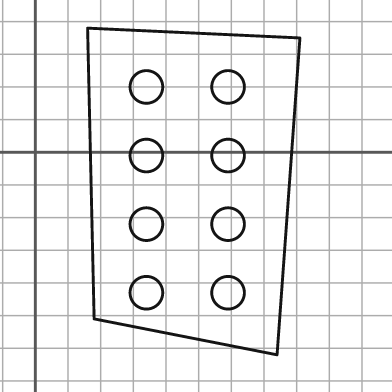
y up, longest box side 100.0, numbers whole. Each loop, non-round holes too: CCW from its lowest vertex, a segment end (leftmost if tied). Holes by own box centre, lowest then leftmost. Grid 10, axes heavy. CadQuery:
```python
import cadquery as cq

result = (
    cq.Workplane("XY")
    .moveTo(74.0, -62.0)
    .lineTo(81.0, 35.0)
    .lineTo(16.0, 38.0)
    .lineTo(18.0, -51.0)
    .close()
    .moveTo(34.0, -43.0)
    .circle(5.0)
    .moveTo(59.0, -43.0)
    .circle(5.0)
    .moveTo(34.0, -22.0)
    .circle(5.0)
    .moveTo(59.0, -22.0)
    .circle(5.0)
    .moveTo(34.0, -1.0)
    .circle(5.0)
    .moveTo(59.0, -1.0)
    .circle(5.0)
    .moveTo(34.0, 20.0)
    .circle(5.0)
    .moveTo(59.0, 20.0)
    .circle(5.0)
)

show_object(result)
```